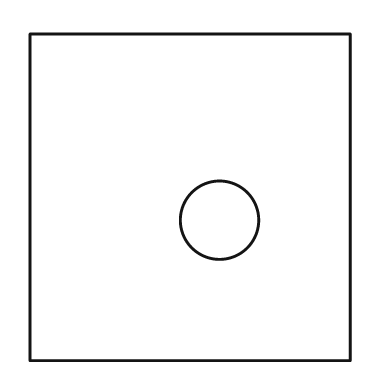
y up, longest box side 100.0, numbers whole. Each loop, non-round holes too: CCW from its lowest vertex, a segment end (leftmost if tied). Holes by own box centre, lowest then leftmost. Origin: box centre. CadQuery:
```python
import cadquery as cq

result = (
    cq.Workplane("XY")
    .moveTo(-49.0, -50.0)
    .lineTo(49.0, -50.0)
    .lineTo(49.0, 50.0)
    .lineTo(-49.0, 50.0)
    .close()
    .moveTo(9.0, -7.0)
    .circle(12.0)
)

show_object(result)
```